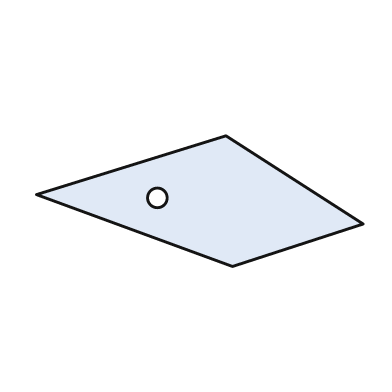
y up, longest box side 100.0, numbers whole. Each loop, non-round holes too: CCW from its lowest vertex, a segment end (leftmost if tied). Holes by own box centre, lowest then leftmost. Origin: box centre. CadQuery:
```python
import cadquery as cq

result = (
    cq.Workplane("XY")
    .moveTo(10.0, -20.0)
    .lineTo(50.0, -7.0)
    .lineTo(8.0, 20.0)
    .lineTo(-50.0, 2.0)
    .close()
    .moveTo(-13.0, 1.0)
    .circle(3.0)
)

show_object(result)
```